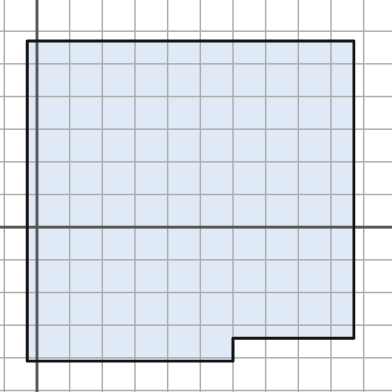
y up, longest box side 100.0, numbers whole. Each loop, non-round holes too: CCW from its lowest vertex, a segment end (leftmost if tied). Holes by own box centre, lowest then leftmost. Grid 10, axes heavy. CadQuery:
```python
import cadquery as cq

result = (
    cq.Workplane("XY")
    .moveTo(-3.0, -41.0)
    .lineTo(60.0, -41.0)
    .lineTo(60.0, -34.0)
    .lineTo(97.0, -34.0)
    .lineTo(97.0, 57.0)
    .lineTo(-3.0, 57.0)
    .close()
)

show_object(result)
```